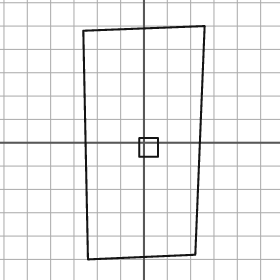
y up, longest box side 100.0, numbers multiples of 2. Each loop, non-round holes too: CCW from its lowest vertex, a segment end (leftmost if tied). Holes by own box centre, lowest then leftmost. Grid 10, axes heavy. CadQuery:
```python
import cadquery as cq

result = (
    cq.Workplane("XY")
    .moveTo(-24.0, -50.0)
    .lineTo(22.0, -48.0)
    .lineTo(26.0, 50.0)
    .lineTo(-26.0, 48.0)
    .close()
    .moveTo(-2.0, -6.0)
    .lineTo(6.0, -6.0)
    .lineTo(6.0, 2.0)
    .lineTo(-2.0, 2.0)
    .close()
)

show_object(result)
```